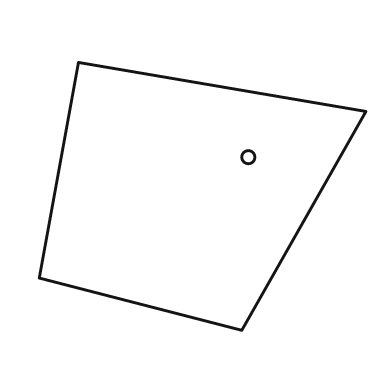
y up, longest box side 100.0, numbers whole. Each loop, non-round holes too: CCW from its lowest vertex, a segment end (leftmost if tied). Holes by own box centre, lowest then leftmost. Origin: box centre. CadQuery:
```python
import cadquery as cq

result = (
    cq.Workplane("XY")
    .moveTo(12.0, -41.0)
    .lineTo(50.0, 26.0)
    .lineTo(-38.0, 41.0)
    .lineTo(-50.0, -25.0)
    .close()
    .moveTo(14.0, 12.0)
    .circle(2.0)
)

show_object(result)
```